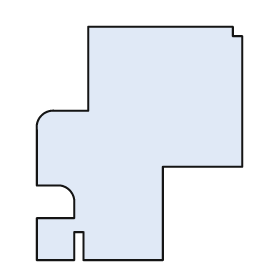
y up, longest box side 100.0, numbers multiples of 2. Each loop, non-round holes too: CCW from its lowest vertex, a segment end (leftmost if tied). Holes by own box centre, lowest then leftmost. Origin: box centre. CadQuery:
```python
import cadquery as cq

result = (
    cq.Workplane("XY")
    .moveTo(-44.0, -50.0)
    .lineTo(-28.0, -50.0)
    .lineTo(-28.0, -38.0)
    .lineTo(-24.0, -38.0)
    .lineTo(-24.0, -50.0)
    .lineTo(10.0, -50.0)
    .lineTo(10.0, -10.0)
    .lineTo(44.0, -10.0)
    .lineTo(44.0, 46.0)
    .lineTo(40.0, 46.0)
    .lineTo(40.0, 50.0)
    .lineTo(-22.0, 50.0)
    .lineTo(-22.0, 14.0)
    .lineTo(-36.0, 14.0)
    .threePointArc((-42.0, 12.0), (-44.0, 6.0))
    .lineTo(-44.0, -18.0)
    .lineTo(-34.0, -18.0)
    .threePointArc((-30.0, -20.0), (-28.0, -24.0))
    .lineTo(-28.0, -32.0)
    .lineTo(-44.0, -32.0)
    .close()
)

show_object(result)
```